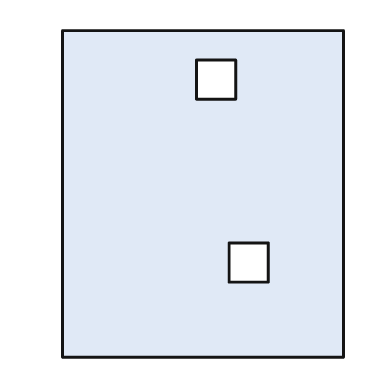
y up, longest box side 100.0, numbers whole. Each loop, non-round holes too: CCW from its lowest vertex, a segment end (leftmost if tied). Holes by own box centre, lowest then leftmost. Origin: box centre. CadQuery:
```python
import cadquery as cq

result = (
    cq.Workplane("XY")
    .moveTo(-43.0, -50.0)
    .lineTo(43.0, -50.0)
    .lineTo(43.0, 50.0)
    .lineTo(-43.0, 50.0)
    .close()
    .moveTo(8.0, -27.0)
    .lineTo(20.0, -27.0)
    .lineTo(20.0, -15.0)
    .lineTo(8.0, -15.0)
    .close()
    .moveTo(-2.0, 29.0)
    .lineTo(10.0, 29.0)
    .lineTo(10.0, 41.0)
    .lineTo(-2.0, 41.0)
    .close()
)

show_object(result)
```